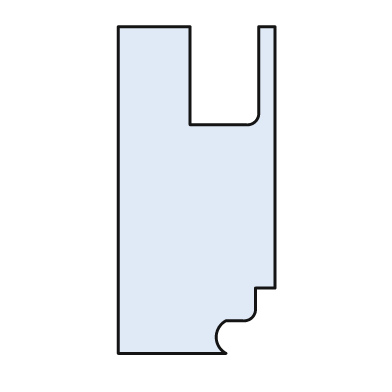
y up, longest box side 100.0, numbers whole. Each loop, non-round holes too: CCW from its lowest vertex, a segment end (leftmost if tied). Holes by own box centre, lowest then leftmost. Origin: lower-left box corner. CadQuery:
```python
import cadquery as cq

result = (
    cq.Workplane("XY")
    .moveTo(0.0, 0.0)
    .lineTo(33.0, 0.0)
    .threePointArc((30.0, 5.0), (33.0, 10.0))
    .lineTo(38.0, 10.0)
    .threePointArc((41.0, 11.0), (42.0, 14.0))
    .lineTo(42.0, 20.0)
    .lineTo(48.0, 20.0)
    .lineTo(48.0, 100.0)
    .lineTo(43.0, 100.0)
    .lineTo(43.0, 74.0)
    .threePointArc((42.0, 71.0), (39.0, 70.0))
    .lineTo(22.0, 70.0)
    .lineTo(22.0, 100.0)
    .lineTo(0.0, 100.0)
    .close()
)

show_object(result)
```